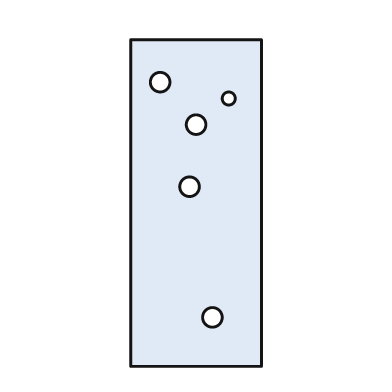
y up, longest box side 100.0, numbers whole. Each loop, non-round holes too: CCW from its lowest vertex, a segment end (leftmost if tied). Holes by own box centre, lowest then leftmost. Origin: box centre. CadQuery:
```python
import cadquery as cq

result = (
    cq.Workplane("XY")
    .moveTo(-20.0, -50.0)
    .lineTo(20.0, -50.0)
    .lineTo(20.0, 50.0)
    .lineTo(-20.0, 50.0)
    .close()
    .moveTo(5.0, -35.0)
    .circle(3.0)
    .moveTo(-2.0, 5.0)
    .circle(3.0)
    .moveTo(0.0, 24.0)
    .circle(3.0)
    .moveTo(10.0, 32.0)
    .circle(2.0)
    .moveTo(-11.0, 37.0)
    .circle(3.0)
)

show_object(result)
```